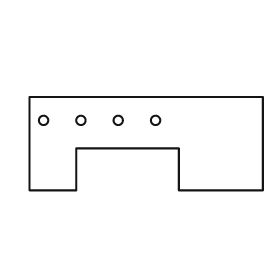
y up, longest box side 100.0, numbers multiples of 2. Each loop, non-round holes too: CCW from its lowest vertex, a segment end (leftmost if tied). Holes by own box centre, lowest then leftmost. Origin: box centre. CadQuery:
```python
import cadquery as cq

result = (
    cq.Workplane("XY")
    .moveTo(-50.0, -20.0)
    .lineTo(-30.0, -20.0)
    .lineTo(-30.0, -2.0)
    .lineTo(14.0, -2.0)
    .lineTo(14.0, -20.0)
    .lineTo(50.0, -20.0)
    .lineTo(50.0, 20.0)
    .lineTo(-50.0, 20.0)
    .close()
    .moveTo(-44.0, 10.0)
    .circle(2.0)
    .moveTo(-28.0, 10.0)
    .circle(2.0)
    .moveTo(-12.0, 10.0)
    .circle(2.0)
    .moveTo(4.0, 10.0)
    .circle(2.0)
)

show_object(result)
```